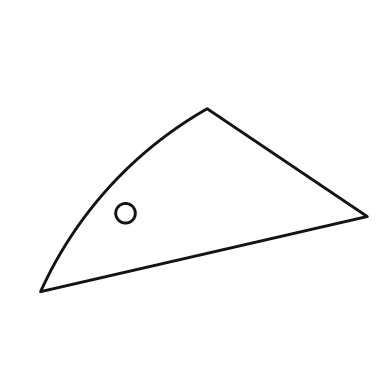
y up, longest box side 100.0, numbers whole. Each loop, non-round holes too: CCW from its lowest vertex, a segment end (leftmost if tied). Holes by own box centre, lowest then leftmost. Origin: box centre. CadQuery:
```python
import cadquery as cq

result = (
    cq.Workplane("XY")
    .moveTo(-50.0, -28.0)
    .lineTo(50.0, -5.0)
    .lineTo(1.0, 28.0)
    .threePointArc((-29.0, 4.0), (-50.0, -28.0))
    .close()
    .moveTo(-24.0, -4.0)
    .circle(3.0)
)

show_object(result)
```